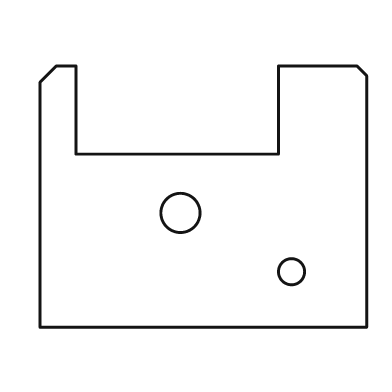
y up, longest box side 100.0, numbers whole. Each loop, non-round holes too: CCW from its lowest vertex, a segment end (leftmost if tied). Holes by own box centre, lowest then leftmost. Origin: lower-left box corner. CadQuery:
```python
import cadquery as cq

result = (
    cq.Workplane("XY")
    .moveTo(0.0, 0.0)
    .lineTo(100.0, 0.0)
    .lineTo(100.0, 77.0)
    .lineTo(97.0, 80.0)
    .lineTo(73.0, 80.0)
    .lineTo(73.0, 53.0)
    .lineTo(11.0, 53.0)
    .lineTo(11.0, 80.0)
    .lineTo(5.0, 80.0)
    .lineTo(0.0, 75.0)
    .close()
    .moveTo(77.0, 17.0)
    .circle(4.0)
    .moveTo(43.0, 35.0)
    .circle(6.0)
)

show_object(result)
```